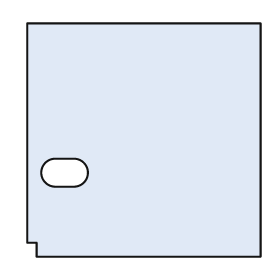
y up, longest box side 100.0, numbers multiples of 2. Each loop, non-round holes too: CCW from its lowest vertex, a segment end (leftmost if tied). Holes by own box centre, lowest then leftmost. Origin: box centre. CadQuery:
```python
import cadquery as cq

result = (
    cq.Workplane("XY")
    .moveTo(-46.0, -50.0)
    .lineTo(50.0, -50.0)
    .lineTo(50.0, 50.0)
    .lineTo(-50.0, 50.0)
    .lineTo(-50.0, -44.0)
    .lineTo(-46.0, -44.0)
    .close()
    .moveTo(-38.0, -20.0)
    .lineTo(-30.0, -20.0)
    .threePointArc((-24.0, -14.0), (-30.0, -8.0))
    .lineTo(-38.0, -8.0)
    .threePointArc((-44.0, -14.0), (-38.0, -20.0))
    .close()
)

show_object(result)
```